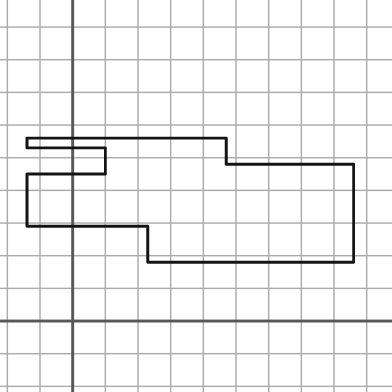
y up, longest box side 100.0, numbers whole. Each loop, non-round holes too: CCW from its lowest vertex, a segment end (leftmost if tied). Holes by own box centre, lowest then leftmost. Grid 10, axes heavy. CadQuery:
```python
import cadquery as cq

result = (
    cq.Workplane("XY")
    .moveTo(23.0, 18.0)
    .lineTo(86.0, 18.0)
    .lineTo(86.0, 48.0)
    .lineTo(47.0, 48.0)
    .lineTo(47.0, 56.0)
    .lineTo(-14.0, 56.0)
    .lineTo(-14.0, 53.0)
    .lineTo(10.0, 53.0)
    .lineTo(10.0, 45.0)
    .lineTo(-14.0, 45.0)
    .lineTo(-14.0, 29.0)
    .lineTo(23.0, 29.0)
    .close()
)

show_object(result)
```